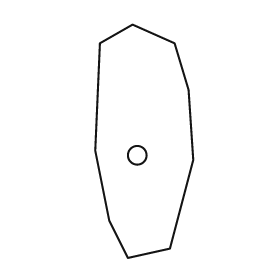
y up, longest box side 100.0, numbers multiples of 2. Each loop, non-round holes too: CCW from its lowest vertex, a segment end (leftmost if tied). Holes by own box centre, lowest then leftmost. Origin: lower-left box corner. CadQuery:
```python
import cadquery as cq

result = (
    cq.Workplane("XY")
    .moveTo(14.0, 0.0)
    .lineTo(32.0, 4.0)
    .lineTo(42.0, 42.0)
    .lineTo(40.0, 72.0)
    .lineTo(34.0, 92.0)
    .lineTo(16.0, 100.0)
    .lineTo(2.0, 92.0)
    .lineTo(0.0, 46.0)
    .lineTo(6.0, 16.0)
    .close()
    .moveTo(18.0, 44.0)
    .circle(4.0)
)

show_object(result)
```